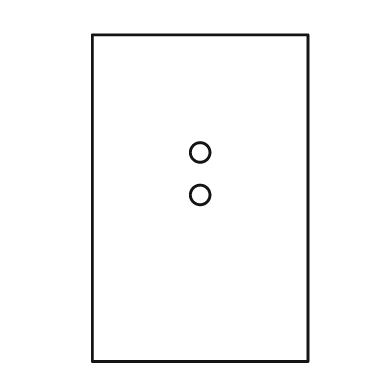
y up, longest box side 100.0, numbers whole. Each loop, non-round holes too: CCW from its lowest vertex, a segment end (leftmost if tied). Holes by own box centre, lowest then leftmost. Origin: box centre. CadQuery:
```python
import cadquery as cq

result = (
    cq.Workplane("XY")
    .moveTo(-33.0, -50.0)
    .lineTo(33.0, -50.0)
    .lineTo(33.0, 50.0)
    .lineTo(-33.0, 50.0)
    .close()
    .moveTo(0.0, 1.0)
    .circle(3.0)
    .moveTo(0.0, 14.0)
    .circle(3.0)
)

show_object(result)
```